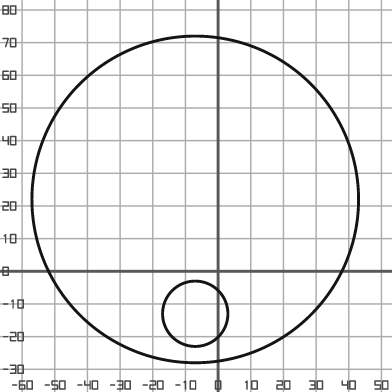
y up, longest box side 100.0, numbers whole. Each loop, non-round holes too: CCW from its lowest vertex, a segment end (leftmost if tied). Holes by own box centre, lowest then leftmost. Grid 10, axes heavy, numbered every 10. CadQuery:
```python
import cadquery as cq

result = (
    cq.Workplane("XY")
    .moveTo(-7.0, 22.0)
    .circle(50.0)
    .moveTo(-7.0, -13.0)
    .circle(10.0)
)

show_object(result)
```